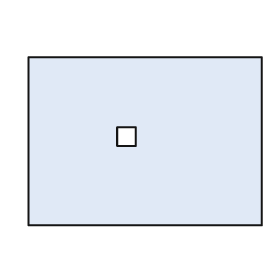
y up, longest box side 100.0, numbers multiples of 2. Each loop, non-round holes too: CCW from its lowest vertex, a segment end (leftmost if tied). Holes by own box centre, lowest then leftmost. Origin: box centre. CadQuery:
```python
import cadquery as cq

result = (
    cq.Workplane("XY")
    .moveTo(-50.0, -36.0)
    .lineTo(50.0, -36.0)
    .lineTo(50.0, 36.0)
    .lineTo(-50.0, 36.0)
    .close()
    .moveTo(-12.0, -2.0)
    .lineTo(-4.0, -2.0)
    .lineTo(-4.0, 6.0)
    .lineTo(-12.0, 6.0)
    .close()
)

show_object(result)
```